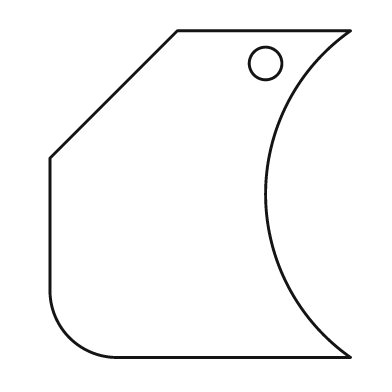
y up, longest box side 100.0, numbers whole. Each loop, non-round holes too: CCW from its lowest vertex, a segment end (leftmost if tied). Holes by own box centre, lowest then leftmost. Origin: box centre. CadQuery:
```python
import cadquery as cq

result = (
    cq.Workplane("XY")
    .moveTo(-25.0, -50.0)
    .lineTo(46.0, -50.0)
    .threePointArc((20.0, 0.0), (46.0, 50.0))
    .lineTo(-7.0, 50.0)
    .lineTo(-46.0, 11.0)
    .lineTo(-46.0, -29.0)
    .threePointArc((-40.0, -44.0), (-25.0, -50.0))
    .close()
    .moveTo(20.0, 40.0)
    .circle(5.0)
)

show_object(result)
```